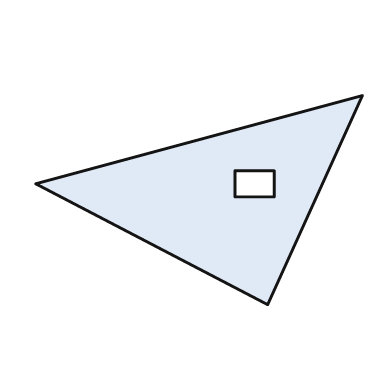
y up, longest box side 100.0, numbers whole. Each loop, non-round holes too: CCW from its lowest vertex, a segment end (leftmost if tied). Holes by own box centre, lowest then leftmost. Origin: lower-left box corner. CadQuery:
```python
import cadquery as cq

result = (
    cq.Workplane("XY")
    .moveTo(71.0, 0.0)
    .lineTo(100.0, 64.0)
    .lineTo(0.0, 37.0)
    .close()
    .moveTo(61.0, 33.0)
    .lineTo(73.0, 33.0)
    .lineTo(73.0, 41.0)
    .lineTo(61.0, 41.0)
    .close()
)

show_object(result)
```